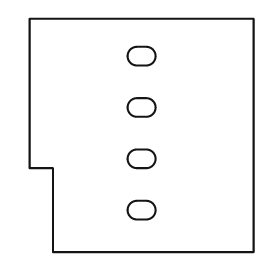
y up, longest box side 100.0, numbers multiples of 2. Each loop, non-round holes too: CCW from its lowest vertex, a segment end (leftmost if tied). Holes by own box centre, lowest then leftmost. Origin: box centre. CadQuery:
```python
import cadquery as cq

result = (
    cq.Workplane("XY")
    .moveTo(-38.0, -50.0)
    .lineTo(48.0, -50.0)
    .lineTo(48.0, 50.0)
    .lineTo(-48.0, 50.0)
    .lineTo(-48.0, -14.0)
    .lineTo(-38.0, -14.0)
    .close()
    .moveTo(-2.0, -36.0)
    .lineTo(2.0, -36.0)
    .threePointArc((6.0, -32.0), (2.0, -28.0))
    .lineTo(-2.0, -28.0)
    .threePointArc((-6.0, -32.0), (-2.0, -36.0))
    .close()
    .moveTo(-2.0, -14.0)
    .lineTo(2.0, -14.0)
    .threePointArc((6.0, -10.0), (2.0, -6.0))
    .lineTo(-2.0, -6.0)
    .threePointArc((-6.0, -10.0), (-2.0, -14.0))
    .close()
    .moveTo(-2.0, 8.0)
    .lineTo(2.0, 8.0)
    .threePointArc((6.0, 12.0), (2.0, 16.0))
    .lineTo(-2.0, 16.0)
    .threePointArc((-6.0, 12.0), (-2.0, 8.0))
    .close()
    .moveTo(-2.0, 30.0)
    .lineTo(2.0, 30.0)
    .threePointArc((6.0, 34.0), (2.0, 38.0))
    .lineTo(-2.0, 38.0)
    .threePointArc((-6.0, 34.0), (-2.0, 30.0))
    .close()
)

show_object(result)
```